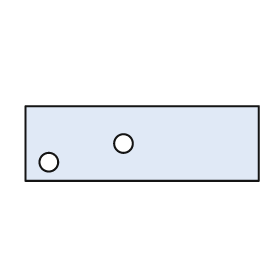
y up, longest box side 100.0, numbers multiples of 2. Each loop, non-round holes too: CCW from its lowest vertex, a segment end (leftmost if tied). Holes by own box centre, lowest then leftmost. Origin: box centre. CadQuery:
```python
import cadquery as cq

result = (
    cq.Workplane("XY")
    .moveTo(-50.0, -16.0)
    .lineTo(50.0, -16.0)
    .lineTo(50.0, 16.0)
    .lineTo(-50.0, 16.0)
    .close()
    .moveTo(-40.0, -8.0)
    .circle(4.0)
    .moveTo(-8.0, 0.0)
    .circle(4.0)
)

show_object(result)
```